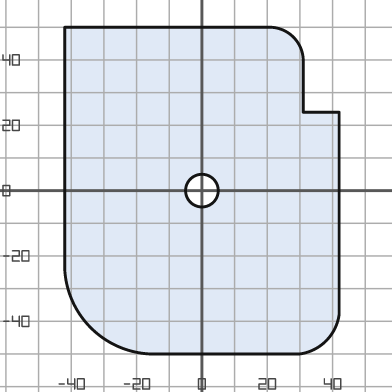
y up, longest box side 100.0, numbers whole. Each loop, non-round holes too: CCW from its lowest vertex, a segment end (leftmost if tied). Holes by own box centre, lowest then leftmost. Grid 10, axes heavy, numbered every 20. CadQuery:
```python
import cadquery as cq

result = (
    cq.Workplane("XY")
    .moveTo(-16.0, -50.0)
    .lineTo(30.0, -50.0)
    .threePointArc((38.0, -46.0), (42.0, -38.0))
    .lineTo(42.0, 24.0)
    .lineTo(31.0, 24.0)
    .lineTo(31.0, 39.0)
    .threePointArc((28.0, 47.0), (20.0, 50.0))
    .lineTo(-42.0, 50.0)
    .lineTo(-42.0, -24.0)
    .threePointArc((-34.0, -42.0), (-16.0, -50.0))
    .close()
    .moveTo(0.0, 0.0)
    .circle(5.0)
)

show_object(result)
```